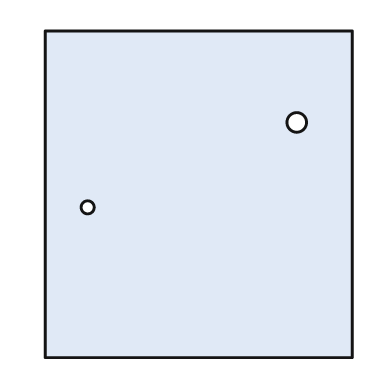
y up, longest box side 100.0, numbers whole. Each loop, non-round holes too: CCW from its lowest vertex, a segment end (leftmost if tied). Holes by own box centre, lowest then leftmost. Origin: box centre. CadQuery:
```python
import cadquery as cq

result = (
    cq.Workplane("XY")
    .moveTo(-47.0, -50.0)
    .lineTo(47.0, -50.0)
    .lineTo(47.0, 50.0)
    .lineTo(-47.0, 50.0)
    .close()
    .moveTo(-34.0, -4.0)
    .circle(2.0)
    .moveTo(30.0, 22.0)
    .circle(3.0)
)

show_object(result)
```